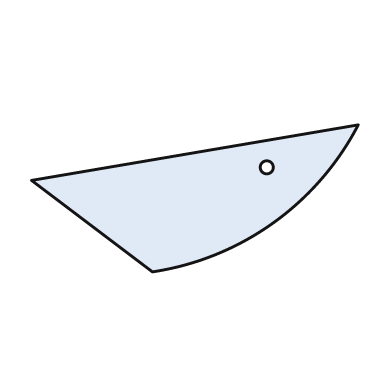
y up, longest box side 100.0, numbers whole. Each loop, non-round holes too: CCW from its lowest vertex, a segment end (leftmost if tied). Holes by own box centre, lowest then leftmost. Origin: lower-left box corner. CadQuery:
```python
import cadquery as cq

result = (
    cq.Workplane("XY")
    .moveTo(37.0, 0.0)
    .threePointArc((74.0, 15.0), (100.0, 45.0))
    .lineTo(0.0, 28.0)
    .close()
    .moveTo(72.0, 32.0)
    .circle(2.0)
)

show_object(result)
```